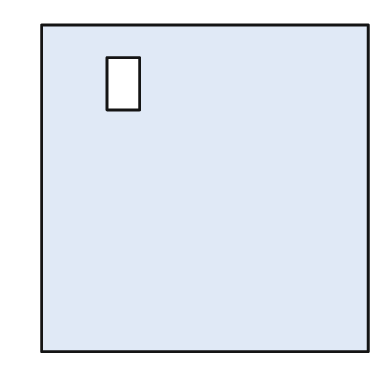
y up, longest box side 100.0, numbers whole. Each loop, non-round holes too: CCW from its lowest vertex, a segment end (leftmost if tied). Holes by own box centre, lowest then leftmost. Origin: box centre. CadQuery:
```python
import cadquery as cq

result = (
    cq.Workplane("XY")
    .moveTo(-50.0, -50.0)
    .lineTo(50.0, -50.0)
    .lineTo(50.0, 50.0)
    .lineTo(-50.0, 50.0)
    .close()
    .moveTo(-30.0, 24.0)
    .lineTo(-20.0, 24.0)
    .lineTo(-20.0, 40.0)
    .lineTo(-30.0, 40.0)
    .close()
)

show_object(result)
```